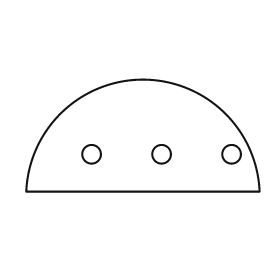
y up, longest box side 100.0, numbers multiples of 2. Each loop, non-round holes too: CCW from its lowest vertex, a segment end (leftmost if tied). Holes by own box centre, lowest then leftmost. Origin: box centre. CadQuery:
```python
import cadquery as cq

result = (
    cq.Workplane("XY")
    .moveTo(-50.0, -24.0)
    .lineTo(50.0, -24.0)
    .threePointArc((0.0, 24.0), (-50.0, -24.0))
    .close()
    .moveTo(-22.0, -8.0)
    .circle(4.0)
    .moveTo(8.0, -8.0)
    .circle(4.0)
    .moveTo(38.0, -8.0)
    .circle(4.0)
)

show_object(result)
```